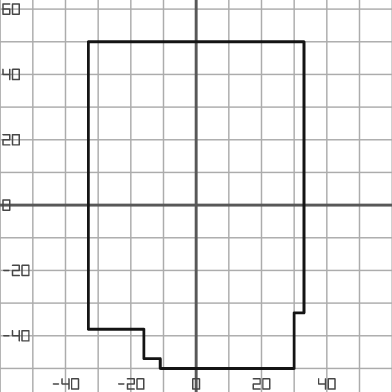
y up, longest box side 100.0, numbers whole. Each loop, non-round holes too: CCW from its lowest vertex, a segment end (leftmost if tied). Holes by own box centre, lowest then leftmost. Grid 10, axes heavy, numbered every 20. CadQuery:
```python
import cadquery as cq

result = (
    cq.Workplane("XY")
    .moveTo(-11.0, -50.0)
    .lineTo(30.0, -50.0)
    .lineTo(30.0, -33.0)
    .lineTo(33.0, -33.0)
    .lineTo(33.0, 50.0)
    .lineTo(-33.0, 50.0)
    .lineTo(-33.0, -38.0)
    .lineTo(-16.0, -38.0)
    .lineTo(-16.0, -47.0)
    .lineTo(-11.0, -47.0)
    .close()
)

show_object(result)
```